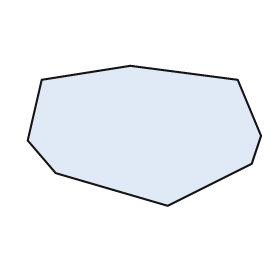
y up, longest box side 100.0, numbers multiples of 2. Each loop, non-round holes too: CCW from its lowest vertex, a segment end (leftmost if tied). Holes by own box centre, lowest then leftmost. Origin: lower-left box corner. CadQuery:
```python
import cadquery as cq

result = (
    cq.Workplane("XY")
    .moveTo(60.0, 0.0)
    .lineTo(96.0, 18.0)
    .lineTo(100.0, 30.0)
    .lineTo(90.0, 54.0)
    .lineTo(44.0, 60.0)
    .lineTo(6.0, 54.0)
    .lineTo(0.0, 28.0)
    .lineTo(12.0, 14.0)
    .close()
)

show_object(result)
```